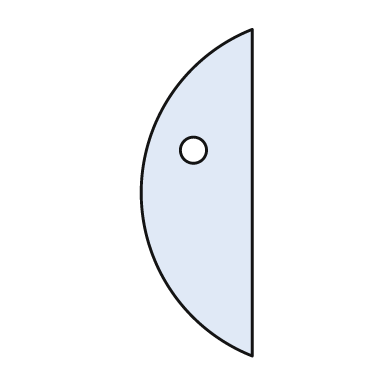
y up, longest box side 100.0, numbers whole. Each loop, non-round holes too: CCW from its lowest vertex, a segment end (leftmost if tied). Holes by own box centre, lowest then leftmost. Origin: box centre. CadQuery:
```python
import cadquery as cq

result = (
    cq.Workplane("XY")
    .moveTo(17.0, -50.0)
    .lineTo(17.0, 50.0)
    .threePointArc((-17.0, 0.0), (17.0, -50.0))
    .close()
    .moveTo(-1.0, 13.0)
    .circle(4.0)
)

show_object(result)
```